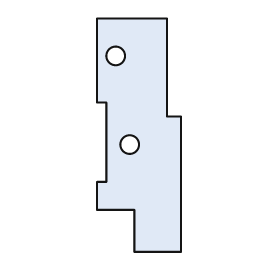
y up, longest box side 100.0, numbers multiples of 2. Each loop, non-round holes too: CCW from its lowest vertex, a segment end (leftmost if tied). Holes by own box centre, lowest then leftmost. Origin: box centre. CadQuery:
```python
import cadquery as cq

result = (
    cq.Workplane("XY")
    .moveTo(-2.0, -50.0)
    .lineTo(18.0, -50.0)
    .lineTo(18.0, 8.0)
    .lineTo(12.0, 8.0)
    .lineTo(12.0, 50.0)
    .lineTo(-18.0, 50.0)
    .lineTo(-18.0, 14.0)
    .lineTo(-14.0, 14.0)
    .lineTo(-14.0, -20.0)
    .lineTo(-18.0, -20.0)
    .lineTo(-18.0, -32.0)
    .lineTo(-2.0, -32.0)
    .close()
    .moveTo(-4.0, -4.0)
    .circle(4.0)
    .moveTo(-10.0, 34.0)
    .circle(4.0)
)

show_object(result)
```